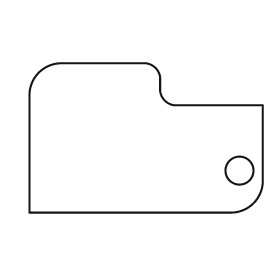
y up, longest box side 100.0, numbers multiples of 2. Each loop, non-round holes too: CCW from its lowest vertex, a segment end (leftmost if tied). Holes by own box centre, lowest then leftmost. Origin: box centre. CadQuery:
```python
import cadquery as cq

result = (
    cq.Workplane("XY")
    .moveTo(-50.0, -32.0)
    .lineTo(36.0, -32.0)
    .threePointArc((46.0, -28.0), (50.0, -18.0))
    .lineTo(50.0, 14.0)
    .lineTo(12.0, 14.0)
    .threePointArc((8.0, 16.0), (6.0, 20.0))
    .lineTo(6.0, 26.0)
    .threePointArc((4.0, 30.0), (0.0, 32.0))
    .lineTo(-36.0, 32.0)
    .threePointArc((-46.0, 28.0), (-50.0, 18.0))
    .close()
    .moveTo(40.0, -14.0)
    .circle(6.0)
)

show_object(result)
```